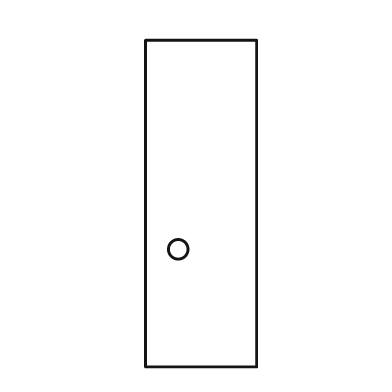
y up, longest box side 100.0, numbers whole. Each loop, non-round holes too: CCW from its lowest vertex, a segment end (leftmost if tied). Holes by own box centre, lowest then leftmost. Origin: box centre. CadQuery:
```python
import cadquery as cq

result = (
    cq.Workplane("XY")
    .moveTo(-17.0, -50.0)
    .lineTo(17.0, -50.0)
    .lineTo(17.0, 50.0)
    .lineTo(-17.0, 50.0)
    .close()
    .moveTo(-7.0, -14.0)
    .circle(3.0)
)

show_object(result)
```